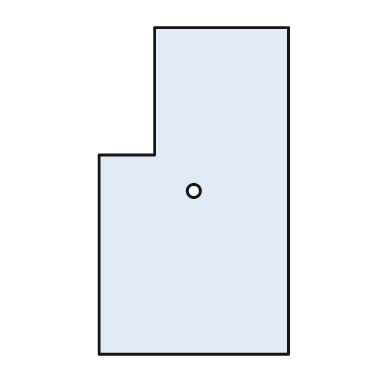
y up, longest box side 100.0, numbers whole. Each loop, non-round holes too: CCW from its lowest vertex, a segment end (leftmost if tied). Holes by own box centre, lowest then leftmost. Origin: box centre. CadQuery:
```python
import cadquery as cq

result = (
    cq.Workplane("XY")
    .moveTo(-29.0, -50.0)
    .lineTo(29.0, -50.0)
    .lineTo(29.0, 50.0)
    .lineTo(-12.0, 50.0)
    .lineTo(-12.0, 11.0)
    .lineTo(-29.0, 11.0)
    .close()
    .moveTo(0.0, 0.0)
    .circle(2.0)
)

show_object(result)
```